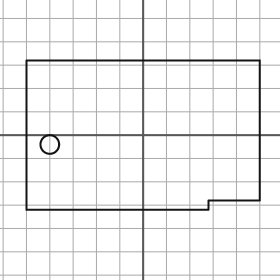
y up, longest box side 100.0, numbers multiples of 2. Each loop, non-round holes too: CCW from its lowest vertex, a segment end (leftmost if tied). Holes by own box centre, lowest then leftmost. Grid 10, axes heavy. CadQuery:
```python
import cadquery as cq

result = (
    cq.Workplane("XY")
    .moveTo(-50.0, -32.0)
    .lineTo(28.0, -32.0)
    .lineTo(28.0, -28.0)
    .lineTo(50.0, -28.0)
    .lineTo(50.0, 32.0)
    .lineTo(-50.0, 32.0)
    .close()
    .moveTo(-40.0, -4.0)
    .circle(4.0)
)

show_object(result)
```